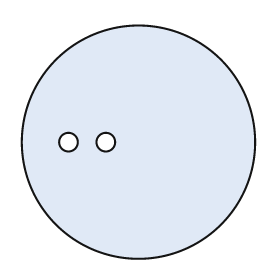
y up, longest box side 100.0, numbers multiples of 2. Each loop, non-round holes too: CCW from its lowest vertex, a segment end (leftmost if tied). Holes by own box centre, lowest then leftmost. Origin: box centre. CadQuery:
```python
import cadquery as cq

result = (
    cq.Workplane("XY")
    .moveTo(0.0, 0.0)
    .circle(50.0)
    .moveTo(-30.0, 0.0)
    .circle(4.0)
    .moveTo(-14.0, 0.0)
    .circle(4.0)
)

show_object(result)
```